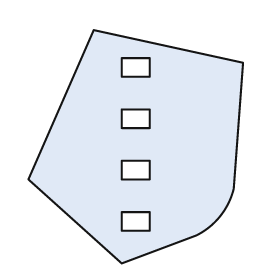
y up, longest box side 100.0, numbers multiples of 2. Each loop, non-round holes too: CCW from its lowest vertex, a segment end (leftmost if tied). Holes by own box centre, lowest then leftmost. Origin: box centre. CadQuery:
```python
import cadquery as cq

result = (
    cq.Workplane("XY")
    .moveTo(-6.0, -50.0)
    .lineTo(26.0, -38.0)
    .threePointArc((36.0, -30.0), (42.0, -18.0))
    .lineTo(46.0, 36.0)
    .lineTo(-18.0, 50.0)
    .lineTo(-46.0, -14.0)
    .close()
    .moveTo(-6.0, -36.0)
    .lineTo(6.0, -36.0)
    .lineTo(6.0, -28.0)
    .lineTo(-6.0, -28.0)
    .close()
    .moveTo(-6.0, -14.0)
    .lineTo(6.0, -14.0)
    .lineTo(6.0, -6.0)
    .lineTo(-6.0, -6.0)
    .close()
    .moveTo(-6.0, 8.0)
    .lineTo(6.0, 8.0)
    .lineTo(6.0, 16.0)
    .lineTo(-6.0, 16.0)
    .close()
    .moveTo(-6.0, 30.0)
    .lineTo(6.0, 30.0)
    .lineTo(6.0, 38.0)
    .lineTo(-6.0, 38.0)
    .close()
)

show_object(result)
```